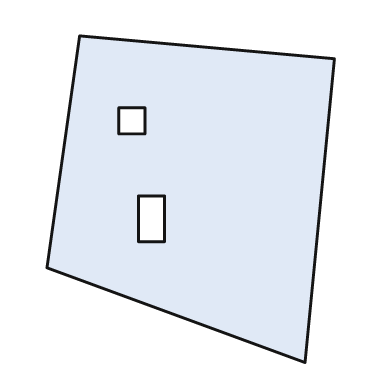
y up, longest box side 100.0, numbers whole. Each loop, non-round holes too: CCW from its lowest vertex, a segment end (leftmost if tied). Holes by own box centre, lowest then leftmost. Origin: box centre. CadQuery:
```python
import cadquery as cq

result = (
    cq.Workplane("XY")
    .moveTo(35.0, -50.0)
    .lineTo(44.0, 43.0)
    .lineTo(-34.0, 50.0)
    .lineTo(-44.0, -21.0)
    .close()
    .moveTo(-16.0, -13.0)
    .lineTo(-8.0, -13.0)
    .lineTo(-8.0, 1.0)
    .lineTo(-16.0, 1.0)
    .close()
    .moveTo(-22.0, 20.0)
    .lineTo(-14.0, 20.0)
    .lineTo(-14.0, 28.0)
    .lineTo(-22.0, 28.0)
    .close()
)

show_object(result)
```